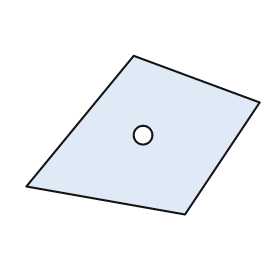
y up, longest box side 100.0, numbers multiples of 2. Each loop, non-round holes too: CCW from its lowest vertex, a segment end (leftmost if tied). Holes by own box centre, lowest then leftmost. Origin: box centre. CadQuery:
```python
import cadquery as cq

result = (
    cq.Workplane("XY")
    .moveTo(18.0, -34.0)
    .lineTo(50.0, 14.0)
    .lineTo(-4.0, 34.0)
    .lineTo(-50.0, -22.0)
    .close()
    .moveTo(0.0, 0.0)
    .circle(4.0)
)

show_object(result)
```